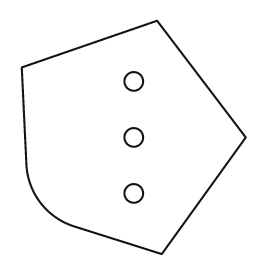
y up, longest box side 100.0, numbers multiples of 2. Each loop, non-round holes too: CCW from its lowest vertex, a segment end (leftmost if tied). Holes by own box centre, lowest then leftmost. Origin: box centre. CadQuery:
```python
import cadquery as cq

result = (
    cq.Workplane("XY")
    .moveTo(12.0, -50.0)
    .lineTo(48.0, 0.0)
    .lineTo(10.0, 50.0)
    .lineTo(-48.0, 30.0)
    .lineTo(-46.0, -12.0)
    .threePointArc((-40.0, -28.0), (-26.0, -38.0))
    .close()
    .moveTo(0.0, -24.0)
    .circle(4.0)
    .moveTo(0.0, 0.0)
    .circle(4.0)
    .moveTo(0.0, 24.0)
    .circle(4.0)
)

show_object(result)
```